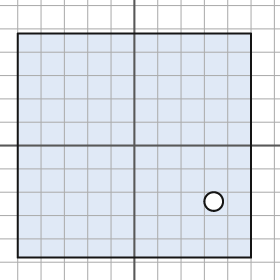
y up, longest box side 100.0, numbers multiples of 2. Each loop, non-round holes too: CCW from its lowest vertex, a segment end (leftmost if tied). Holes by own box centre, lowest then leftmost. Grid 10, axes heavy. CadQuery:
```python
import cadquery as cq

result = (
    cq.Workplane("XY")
    .moveTo(-50.0, -48.0)
    .lineTo(50.0, -48.0)
    .lineTo(50.0, 48.0)
    .lineTo(-50.0, 48.0)
    .close()
    .moveTo(34.0, -24.0)
    .circle(4.0)
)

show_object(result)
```